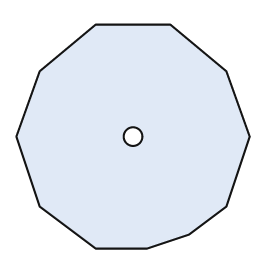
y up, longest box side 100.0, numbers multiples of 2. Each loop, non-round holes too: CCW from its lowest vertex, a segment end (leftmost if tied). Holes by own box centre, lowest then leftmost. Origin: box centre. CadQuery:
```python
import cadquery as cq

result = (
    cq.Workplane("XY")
    .moveTo(-16.0, -48.0)
    .lineTo(6.0, -48.0)
    .lineTo(24.0, -42.0)
    .lineTo(40.0, -30.0)
    .lineTo(50.0, 0.0)
    .lineTo(40.0, 28.0)
    .lineTo(16.0, 48.0)
    .lineTo(-16.0, 48.0)
    .lineTo(-40.0, 28.0)
    .lineTo(-50.0, 0.0)
    .lineTo(-40.0, -30.0)
    .close()
    .moveTo(0.0, 0.0)
    .circle(4.0)
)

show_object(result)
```